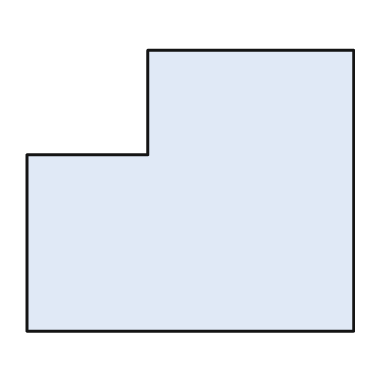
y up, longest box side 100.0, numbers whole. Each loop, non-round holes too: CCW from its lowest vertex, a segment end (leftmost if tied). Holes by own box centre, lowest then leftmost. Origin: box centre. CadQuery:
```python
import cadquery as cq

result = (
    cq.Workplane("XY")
    .moveTo(-50.0, -43.0)
    .lineTo(50.0, -43.0)
    .lineTo(50.0, 43.0)
    .lineTo(-13.0, 43.0)
    .lineTo(-13.0, 11.0)
    .lineTo(-50.0, 11.0)
    .close()
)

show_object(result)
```